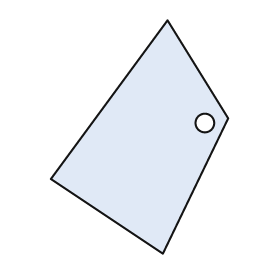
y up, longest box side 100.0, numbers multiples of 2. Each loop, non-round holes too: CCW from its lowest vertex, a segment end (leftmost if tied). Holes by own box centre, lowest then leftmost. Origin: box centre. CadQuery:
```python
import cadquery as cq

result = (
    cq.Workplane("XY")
    .moveTo(10.0, -50.0)
    .lineTo(38.0, 8.0)
    .lineTo(12.0, 50.0)
    .lineTo(-38.0, -18.0)
    .close()
    .moveTo(28.0, 6.0)
    .circle(4.0)
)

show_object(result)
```